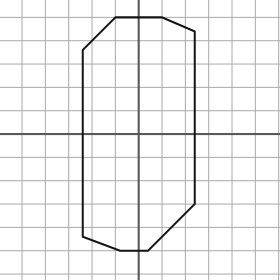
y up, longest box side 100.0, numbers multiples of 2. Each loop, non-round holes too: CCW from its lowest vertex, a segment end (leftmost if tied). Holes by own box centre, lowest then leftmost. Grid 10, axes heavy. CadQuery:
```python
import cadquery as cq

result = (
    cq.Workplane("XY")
    .moveTo(-8.0, -50.0)
    .lineTo(4.0, -50.0)
    .lineTo(24.0, -30.0)
    .lineTo(24.0, 44.0)
    .lineTo(10.0, 50.0)
    .lineTo(-10.0, 50.0)
    .lineTo(-24.0, 36.0)
    .lineTo(-24.0, -44.0)
    .close()
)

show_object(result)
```